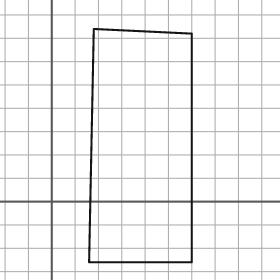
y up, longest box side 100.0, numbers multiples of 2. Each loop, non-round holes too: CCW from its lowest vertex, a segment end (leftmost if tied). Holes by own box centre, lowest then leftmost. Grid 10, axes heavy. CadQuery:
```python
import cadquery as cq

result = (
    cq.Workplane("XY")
    .moveTo(16.0, -26.0)
    .lineTo(60.0, -26.0)
    .lineTo(60.0, 72.0)
    .lineTo(18.0, 74.0)
    .close()
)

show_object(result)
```